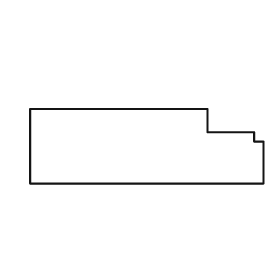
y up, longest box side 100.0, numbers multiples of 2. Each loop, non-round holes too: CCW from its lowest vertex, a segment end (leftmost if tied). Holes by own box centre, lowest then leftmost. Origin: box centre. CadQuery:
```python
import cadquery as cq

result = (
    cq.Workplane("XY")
    .moveTo(-50.0, -16.0)
    .lineTo(50.0, -16.0)
    .lineTo(50.0, 2.0)
    .lineTo(46.0, 2.0)
    .lineTo(46.0, 6.0)
    .lineTo(26.0, 6.0)
    .lineTo(26.0, 16.0)
    .lineTo(-50.0, 16.0)
    .close()
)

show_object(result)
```